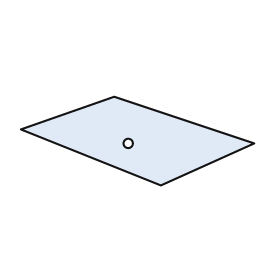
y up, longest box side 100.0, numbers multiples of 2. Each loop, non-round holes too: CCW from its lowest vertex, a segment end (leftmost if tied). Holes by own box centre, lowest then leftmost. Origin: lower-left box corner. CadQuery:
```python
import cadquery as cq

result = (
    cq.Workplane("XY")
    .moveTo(60.0, 0.0)
    .lineTo(100.0, 18.0)
    .lineTo(40.0, 38.0)
    .lineTo(0.0, 24.0)
    .close()
    .moveTo(46.0, 18.0)
    .circle(2.0)
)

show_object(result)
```